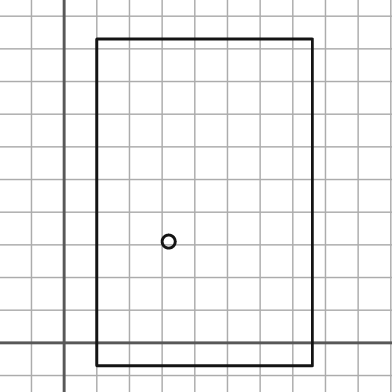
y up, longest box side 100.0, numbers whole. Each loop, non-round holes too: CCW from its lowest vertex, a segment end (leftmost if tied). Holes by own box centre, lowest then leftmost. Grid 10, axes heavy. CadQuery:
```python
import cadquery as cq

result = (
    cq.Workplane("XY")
    .moveTo(10.0, -7.0)
    .lineTo(76.0, -7.0)
    .lineTo(76.0, 93.0)
    .lineTo(10.0, 93.0)
    .close()
    .moveTo(32.0, 31.0)
    .circle(2.0)
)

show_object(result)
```